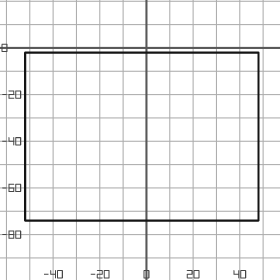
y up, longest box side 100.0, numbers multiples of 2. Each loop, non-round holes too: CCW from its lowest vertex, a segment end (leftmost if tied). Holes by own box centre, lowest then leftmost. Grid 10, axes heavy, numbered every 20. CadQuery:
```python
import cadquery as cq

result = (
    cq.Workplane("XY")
    .moveTo(-52.0, -74.0)
    .lineTo(48.0, -74.0)
    .lineTo(48.0, -2.0)
    .lineTo(-52.0, -2.0)
    .close()
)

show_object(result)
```